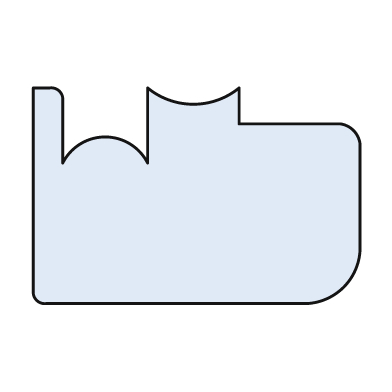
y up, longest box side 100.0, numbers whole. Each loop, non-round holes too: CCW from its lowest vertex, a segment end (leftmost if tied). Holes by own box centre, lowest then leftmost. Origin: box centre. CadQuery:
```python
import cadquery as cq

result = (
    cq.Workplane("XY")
    .moveTo(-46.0, -33.0)
    .lineTo(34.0, -33.0)
    .threePointArc((45.0, -28.0), (50.0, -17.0))
    .lineTo(50.0, 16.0)
    .threePointArc((48.0, 20.0), (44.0, 22.0))
    .lineTo(13.0, 22.0)
    .lineTo(13.0, 33.0)
    .threePointArc((-1.0, 28.0), (-15.0, 33.0))
    .lineTo(-15.0, 10.0)
    .threePointArc((-28.0, 18.0), (-41.0, 10.0))
    .lineTo(-41.0, 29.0)
    .threePointArc((-42.0, 32.0), (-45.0, 33.0))
    .lineTo(-50.0, 33.0)
    .lineTo(-50.0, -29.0)
    .threePointArc((-49.0, -32.0), (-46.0, -33.0))
    .close()
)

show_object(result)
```